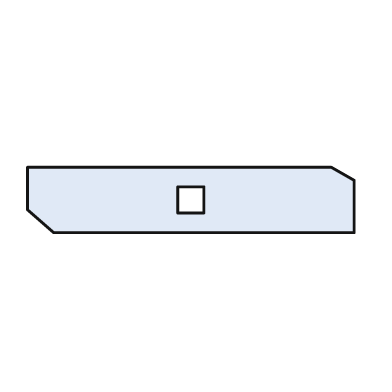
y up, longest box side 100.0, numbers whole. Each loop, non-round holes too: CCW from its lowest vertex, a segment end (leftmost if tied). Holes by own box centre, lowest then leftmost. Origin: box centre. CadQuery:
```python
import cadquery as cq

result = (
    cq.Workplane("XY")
    .moveTo(-42.0, -10.0)
    .lineTo(50.0, -10.0)
    .lineTo(50.0, 6.0)
    .lineTo(43.0, 10.0)
    .lineTo(-50.0, 10.0)
    .lineTo(-50.0, -3.0)
    .close()
    .moveTo(-4.0, -4.0)
    .lineTo(4.0, -4.0)
    .lineTo(4.0, 4.0)
    .lineTo(-4.0, 4.0)
    .close()
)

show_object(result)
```